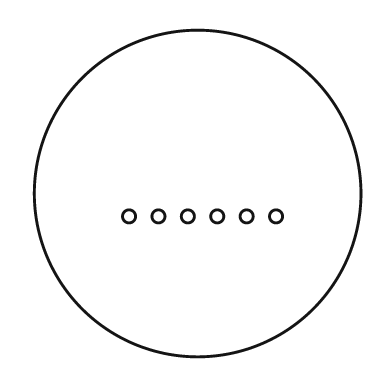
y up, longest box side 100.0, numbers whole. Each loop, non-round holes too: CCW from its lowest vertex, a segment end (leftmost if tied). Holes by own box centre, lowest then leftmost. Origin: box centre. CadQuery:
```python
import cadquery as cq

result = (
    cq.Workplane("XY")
    .moveTo(0.0, 0.0)
    .circle(50.0)
    .moveTo(-21.0, -7.0)
    .circle(2.0)
    .moveTo(-12.0, -7.0)
    .circle(2.0)
    .moveTo(-3.0, -7.0)
    .circle(2.0)
    .moveTo(6.0, -7.0)
    .circle(2.0)
    .moveTo(15.0, -7.0)
    .circle(2.0)
    .moveTo(24.0, -7.0)
    .circle(2.0)
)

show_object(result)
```